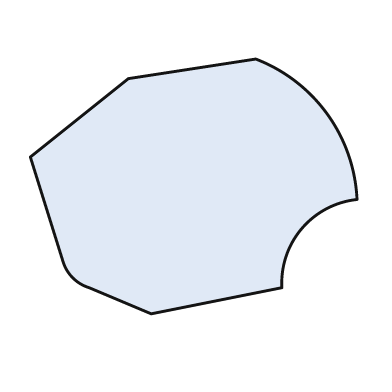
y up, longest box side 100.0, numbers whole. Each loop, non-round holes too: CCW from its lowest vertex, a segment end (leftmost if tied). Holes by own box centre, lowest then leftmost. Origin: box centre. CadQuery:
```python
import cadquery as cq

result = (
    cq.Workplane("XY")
    .moveTo(-13.0, -39.0)
    .lineTo(27.0, -31.0)
    .threePointArc((33.0, -13.0), (50.0, -4.0))
    .threePointArc((41.0, 22.0), (19.0, 39.0))
    .lineTo(-20.0, 33.0)
    .lineTo(-50.0, 9.0)
    .lineTo(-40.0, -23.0)
    .threePointArc((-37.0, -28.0), (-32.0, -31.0))
    .close()
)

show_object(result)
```